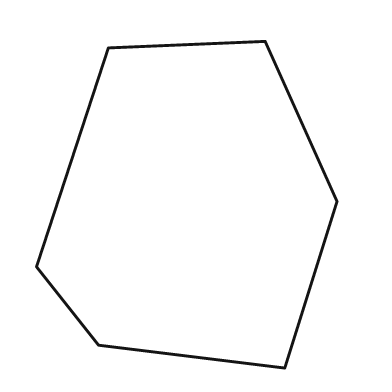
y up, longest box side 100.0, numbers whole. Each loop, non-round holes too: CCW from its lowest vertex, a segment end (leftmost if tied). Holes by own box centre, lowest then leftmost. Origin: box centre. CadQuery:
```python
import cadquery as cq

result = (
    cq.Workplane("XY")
    .moveTo(30.0, -50.0)
    .lineTo(46.0, 1.0)
    .lineTo(24.0, 50.0)
    .lineTo(-24.0, 48.0)
    .lineTo(-46.0, -19.0)
    .lineTo(-27.0, -43.0)
    .close()
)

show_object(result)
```